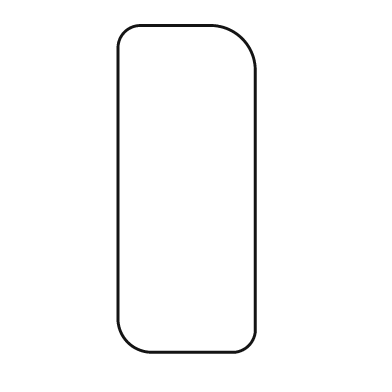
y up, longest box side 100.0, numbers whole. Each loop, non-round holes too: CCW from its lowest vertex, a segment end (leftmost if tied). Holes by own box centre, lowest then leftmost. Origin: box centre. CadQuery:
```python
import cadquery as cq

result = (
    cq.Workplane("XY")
    .moveTo(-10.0, -50.0)
    .lineTo(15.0, -50.0)
    .threePointArc((19.0, -48.0), (21.0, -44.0))
    .lineTo(21.0, 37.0)
    .threePointArc((17.0, 46.0), (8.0, 50.0))
    .lineTo(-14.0, 50.0)
    .threePointArc((-19.0, 48.0), (-21.0, 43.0))
    .lineTo(-21.0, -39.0)
    .threePointArc((-18.0, -47.0), (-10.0, -50.0))
    .close()
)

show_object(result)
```